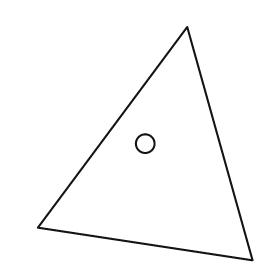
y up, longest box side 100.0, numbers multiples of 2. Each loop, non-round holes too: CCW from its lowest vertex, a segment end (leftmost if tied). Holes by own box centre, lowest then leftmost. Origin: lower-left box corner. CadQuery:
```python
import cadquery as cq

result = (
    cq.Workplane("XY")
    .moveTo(92.0, 0.0)
    .lineTo(64.0, 100.0)
    .lineTo(0.0, 14.0)
    .close()
    .moveTo(46.0, 50.0)
    .circle(4.0)
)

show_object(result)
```